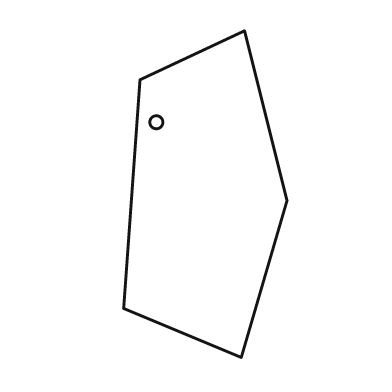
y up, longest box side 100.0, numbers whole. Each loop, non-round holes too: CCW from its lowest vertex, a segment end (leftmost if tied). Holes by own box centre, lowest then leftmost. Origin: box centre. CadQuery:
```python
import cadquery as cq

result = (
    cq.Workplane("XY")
    .moveTo(11.0, -50.0)
    .lineTo(25.0, -2.0)
    .lineTo(12.0, 50.0)
    .lineTo(-20.0, 35.0)
    .lineTo(-25.0, -35.0)
    .close()
    .moveTo(-15.0, 22.0)
    .circle(2.0)
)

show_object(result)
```